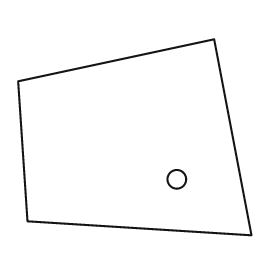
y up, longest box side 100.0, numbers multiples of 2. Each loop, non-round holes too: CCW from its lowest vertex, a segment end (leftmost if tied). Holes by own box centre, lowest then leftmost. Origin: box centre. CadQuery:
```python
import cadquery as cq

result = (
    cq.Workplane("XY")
    .moveTo(50.0, -42.0)
    .lineTo(34.0, 42.0)
    .lineTo(-50.0, 24.0)
    .lineTo(-46.0, -36.0)
    .close()
    .moveTo(18.0, -18.0)
    .circle(4.0)
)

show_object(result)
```